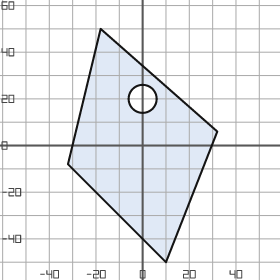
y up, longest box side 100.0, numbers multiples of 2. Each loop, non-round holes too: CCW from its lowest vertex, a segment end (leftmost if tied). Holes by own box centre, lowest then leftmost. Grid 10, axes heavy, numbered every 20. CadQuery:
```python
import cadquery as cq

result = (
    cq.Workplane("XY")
    .moveTo(10.0, -50.0)
    .lineTo(32.0, 6.0)
    .lineTo(-18.0, 50.0)
    .lineTo(-32.0, -8.0)
    .close()
    .moveTo(0.0, 20.0)
    .circle(6.0)
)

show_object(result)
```